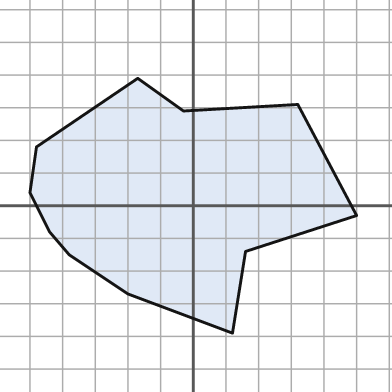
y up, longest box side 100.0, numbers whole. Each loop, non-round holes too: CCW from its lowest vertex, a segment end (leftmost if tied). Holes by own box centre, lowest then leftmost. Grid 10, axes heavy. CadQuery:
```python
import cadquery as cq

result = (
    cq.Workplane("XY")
    .moveTo(12.0, -39.0)
    .lineTo(16.0, -14.0)
    .lineTo(50.0, -3.0)
    .lineTo(32.0, 31.0)
    .lineTo(-3.0, 29.0)
    .lineTo(-17.0, 39.0)
    .lineTo(-48.0, 18.0)
    .lineTo(-50.0, 4.0)
    .lineTo(-44.0, -8.0)
    .lineTo(-38.0, -15.0)
    .lineTo(-20.0, -27.0)
    .close()
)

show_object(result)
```